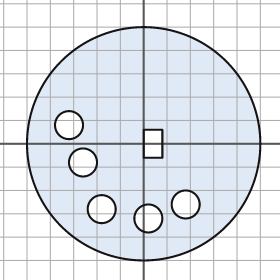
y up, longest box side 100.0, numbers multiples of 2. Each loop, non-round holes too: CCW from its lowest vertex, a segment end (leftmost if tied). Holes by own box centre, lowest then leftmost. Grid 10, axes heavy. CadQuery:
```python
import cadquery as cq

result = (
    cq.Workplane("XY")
    .moveTo(0.0, 0.0)
    .circle(50.0)
    .moveTo(2.0, -32.0)
    .circle(6.0)
    .moveTo(-18.0, -28.0)
    .circle(6.0)
    .moveTo(18.0, -26.0)
    .circle(6.0)
    .moveTo(-26.0, -8.0)
    .circle(6.0)
    .moveTo(0.0, -6.0)
    .lineTo(8.0, -6.0)
    .lineTo(8.0, 6.0)
    .lineTo(0.0, 6.0)
    .close()
    .moveTo(-32.0, 8.0)
    .circle(6.0)
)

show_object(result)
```